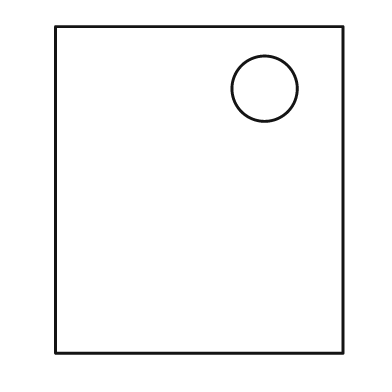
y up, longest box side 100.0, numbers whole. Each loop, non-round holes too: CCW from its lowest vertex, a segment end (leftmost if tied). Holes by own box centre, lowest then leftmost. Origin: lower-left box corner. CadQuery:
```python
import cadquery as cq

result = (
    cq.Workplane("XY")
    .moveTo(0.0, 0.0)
    .lineTo(88.0, 0.0)
    .lineTo(88.0, 100.0)
    .lineTo(0.0, 100.0)
    .close()
    .moveTo(64.0, 81.0)
    .circle(10.0)
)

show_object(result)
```